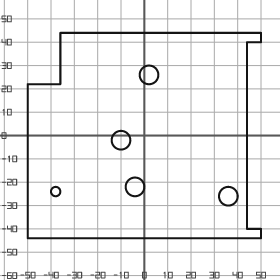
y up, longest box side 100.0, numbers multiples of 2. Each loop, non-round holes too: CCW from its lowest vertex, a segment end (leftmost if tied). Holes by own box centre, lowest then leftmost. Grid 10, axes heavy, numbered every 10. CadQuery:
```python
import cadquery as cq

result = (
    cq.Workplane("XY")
    .moveTo(-50.0, -44.0)
    .lineTo(50.0, -44.0)
    .lineTo(50.0, -40.0)
    .lineTo(44.0, -40.0)
    .lineTo(44.0, 40.0)
    .lineTo(50.0, 40.0)
    .lineTo(50.0, 44.0)
    .lineTo(-36.0, 44.0)
    .lineTo(-36.0, 22.0)
    .lineTo(-50.0, 22.0)
    .close()
    .moveTo(36.0, -26.0)
    .circle(4.0)
    .moveTo(-38.0, -24.0)
    .circle(2.0)
    .moveTo(-4.0, -22.0)
    .circle(4.0)
    .moveTo(-10.0, -2.0)
    .circle(4.0)
    .moveTo(2.0, 26.0)
    .circle(4.0)
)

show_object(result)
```